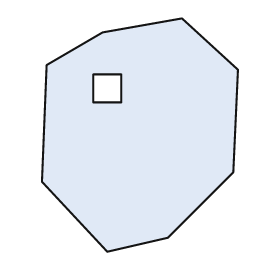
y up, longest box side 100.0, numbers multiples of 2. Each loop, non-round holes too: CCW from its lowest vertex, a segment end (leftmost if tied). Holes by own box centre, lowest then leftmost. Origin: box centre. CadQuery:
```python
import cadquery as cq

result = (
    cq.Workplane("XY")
    .moveTo(-14.0, -50.0)
    .lineTo(12.0, -44.0)
    .lineTo(40.0, -16.0)
    .lineTo(42.0, 28.0)
    .lineTo(18.0, 50.0)
    .lineTo(-16.0, 44.0)
    .lineTo(-40.0, 30.0)
    .lineTo(-42.0, -20.0)
    .close()
    .moveTo(-20.0, 14.0)
    .lineTo(-8.0, 14.0)
    .lineTo(-8.0, 26.0)
    .lineTo(-20.0, 26.0)
    .close()
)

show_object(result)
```